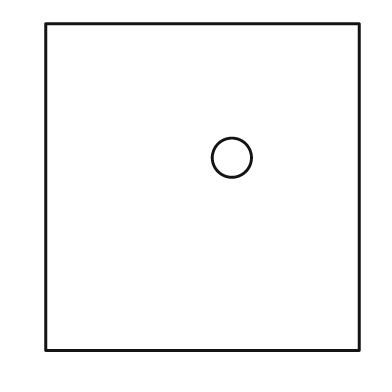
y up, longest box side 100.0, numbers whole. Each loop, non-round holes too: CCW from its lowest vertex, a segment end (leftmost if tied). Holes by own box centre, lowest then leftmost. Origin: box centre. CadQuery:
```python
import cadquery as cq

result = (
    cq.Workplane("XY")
    .moveTo(-48.0, -50.0)
    .lineTo(48.0, -50.0)
    .lineTo(48.0, 50.0)
    .lineTo(-48.0, 50.0)
    .close()
    .moveTo(9.0, 9.0)
    .circle(6.0)
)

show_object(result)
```